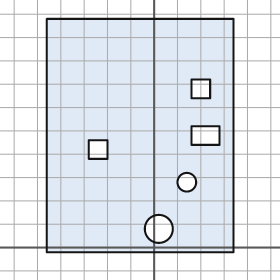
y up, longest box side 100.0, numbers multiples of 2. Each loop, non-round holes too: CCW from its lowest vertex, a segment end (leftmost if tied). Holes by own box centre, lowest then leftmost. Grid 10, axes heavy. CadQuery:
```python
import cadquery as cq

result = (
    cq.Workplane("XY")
    .moveTo(-46.0, -2.0)
    .lineTo(34.0, -2.0)
    .lineTo(34.0, 98.0)
    .lineTo(-46.0, 98.0)
    .close()
    .moveTo(2.0, 8.0)
    .circle(6.0)
    .moveTo(14.0, 28.0)
    .circle(4.0)
    .moveTo(-28.0, 38.0)
    .lineTo(-20.0, 38.0)
    .lineTo(-20.0, 46.0)
    .lineTo(-28.0, 46.0)
    .close()
    .moveTo(16.0, 44.0)
    .lineTo(28.0, 44.0)
    .lineTo(28.0, 52.0)
    .lineTo(16.0, 52.0)
    .close()
    .moveTo(16.0, 64.0)
    .lineTo(24.0, 64.0)
    .lineTo(24.0, 72.0)
    .lineTo(16.0, 72.0)
    .close()
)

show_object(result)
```